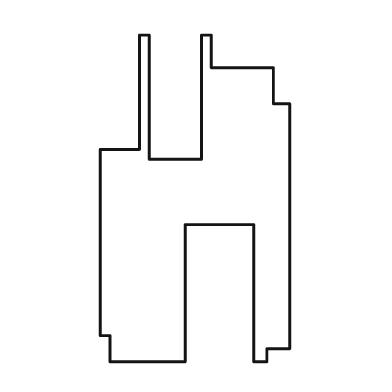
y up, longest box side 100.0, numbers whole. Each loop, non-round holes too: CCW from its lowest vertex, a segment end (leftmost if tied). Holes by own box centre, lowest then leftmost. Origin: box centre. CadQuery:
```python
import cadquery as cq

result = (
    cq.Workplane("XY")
    .moveTo(-26.0, -50.0)
    .lineTo(-3.0, -50.0)
    .lineTo(-3.0, -8.0)
    .lineTo(18.0, -8.0)
    .lineTo(18.0, -50.0)
    .lineTo(22.0, -50.0)
    .lineTo(22.0, -46.0)
    .lineTo(29.0, -46.0)
    .lineTo(29.0, 29.0)
    .lineTo(24.0, 29.0)
    .lineTo(24.0, 40.0)
    .lineTo(5.0, 40.0)
    .lineTo(5.0, 50.0)
    .lineTo(2.0, 50.0)
    .lineTo(2.0, 12.0)
    .lineTo(-14.0, 12.0)
    .lineTo(-14.0, 50.0)
    .lineTo(-17.0, 50.0)
    .lineTo(-17.0, 15.0)
    .lineTo(-29.0, 15.0)
    .lineTo(-29.0, -42.0)
    .lineTo(-26.0, -42.0)
    .close()
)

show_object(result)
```